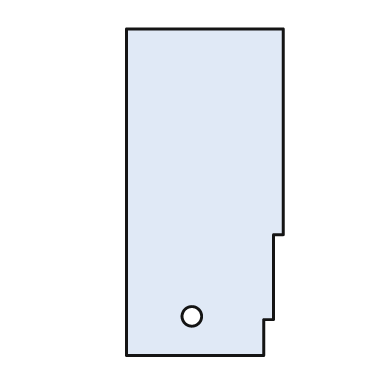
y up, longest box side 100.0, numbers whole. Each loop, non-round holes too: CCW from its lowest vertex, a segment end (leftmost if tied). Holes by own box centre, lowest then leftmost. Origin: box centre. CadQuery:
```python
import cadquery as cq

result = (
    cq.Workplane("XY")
    .moveTo(-24.0, -50.0)
    .lineTo(18.0, -50.0)
    .lineTo(18.0, -39.0)
    .lineTo(21.0, -39.0)
    .lineTo(21.0, -13.0)
    .lineTo(24.0, -13.0)
    .lineTo(24.0, 50.0)
    .lineTo(-24.0, 50.0)
    .close()
    .moveTo(-4.0, -38.0)
    .circle(3.0)
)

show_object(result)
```